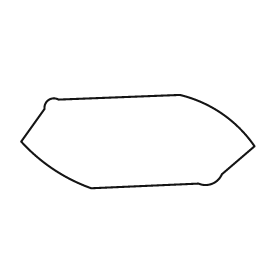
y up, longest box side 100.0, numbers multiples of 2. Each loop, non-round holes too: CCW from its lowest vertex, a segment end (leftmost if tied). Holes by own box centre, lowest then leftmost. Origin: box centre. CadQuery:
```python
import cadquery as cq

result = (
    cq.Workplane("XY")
    .moveTo(-20.0, -20.0)
    .lineTo(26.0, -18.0)
    .threePointArc((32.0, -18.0), (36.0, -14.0))
    .lineTo(50.0, -2.0)
    .threePointArc((36.0, 12.0), (18.0, 20.0))
    .lineTo(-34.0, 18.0)
    .threePointArc((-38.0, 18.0), (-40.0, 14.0))
    .lineTo(-50.0, 0.0)
    .threePointArc((-36.0, -12.0), (-20.0, -20.0))
    .close()
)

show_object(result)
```